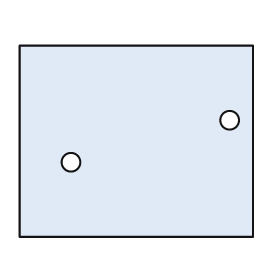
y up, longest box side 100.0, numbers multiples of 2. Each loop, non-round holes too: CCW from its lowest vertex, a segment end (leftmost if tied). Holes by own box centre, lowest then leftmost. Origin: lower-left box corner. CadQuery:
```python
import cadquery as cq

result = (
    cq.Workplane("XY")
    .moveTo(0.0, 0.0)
    .lineTo(100.0, 0.0)
    .lineTo(100.0, 82.0)
    .lineTo(0.0, 82.0)
    .close()
    .moveTo(22.0, 32.0)
    .circle(4.0)
    .moveTo(90.0, 50.0)
    .circle(4.0)
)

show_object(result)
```